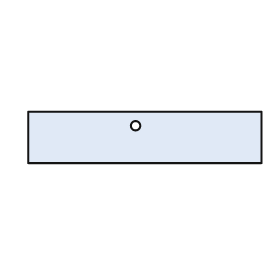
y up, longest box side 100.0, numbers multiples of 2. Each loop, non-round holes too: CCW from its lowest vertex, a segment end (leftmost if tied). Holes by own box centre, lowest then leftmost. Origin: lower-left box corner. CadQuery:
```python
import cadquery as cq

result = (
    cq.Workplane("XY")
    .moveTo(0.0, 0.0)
    .lineTo(100.0, 0.0)
    .lineTo(100.0, 22.0)
    .lineTo(0.0, 22.0)
    .close()
    .moveTo(46.0, 16.0)
    .circle(2.0)
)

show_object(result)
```